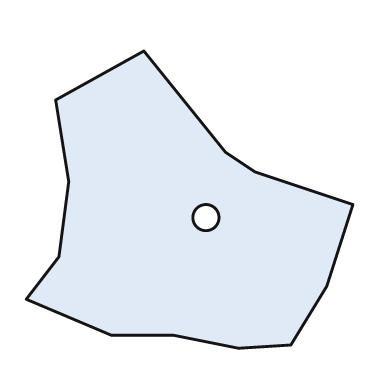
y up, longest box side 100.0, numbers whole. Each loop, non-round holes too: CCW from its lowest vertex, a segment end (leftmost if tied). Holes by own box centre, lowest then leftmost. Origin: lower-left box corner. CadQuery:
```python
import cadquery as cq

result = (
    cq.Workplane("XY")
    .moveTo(65.0, 0.0)
    .lineTo(81.0, 1.0)
    .lineTo(92.0, 19.0)
    .lineTo(100.0, 44.0)
    .lineTo(70.0, 54.0)
    .lineTo(61.0, 60.0)
    .lineTo(36.0, 91.0)
    .lineTo(9.0, 76.0)
    .lineTo(13.0, 51.0)
    .lineTo(10.0, 28.0)
    .lineTo(0.0, 15.0)
    .lineTo(26.0, 4.0)
    .lineTo(45.0, 4.0)
    .close()
    .moveTo(55.0, 40.0)
    .circle(4.0)
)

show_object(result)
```